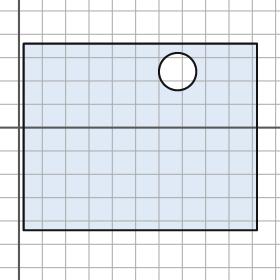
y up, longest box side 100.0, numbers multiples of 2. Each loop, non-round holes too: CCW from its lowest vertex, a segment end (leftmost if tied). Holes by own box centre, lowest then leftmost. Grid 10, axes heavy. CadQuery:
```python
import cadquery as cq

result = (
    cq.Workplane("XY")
    .moveTo(2.0, -44.0)
    .lineTo(102.0, -44.0)
    .lineTo(102.0, 36.0)
    .lineTo(2.0, 36.0)
    .close()
    .moveTo(68.0, 24.0)
    .circle(8.0)
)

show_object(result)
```